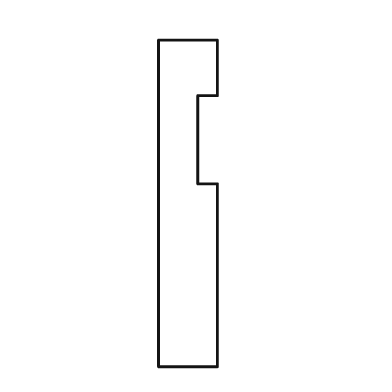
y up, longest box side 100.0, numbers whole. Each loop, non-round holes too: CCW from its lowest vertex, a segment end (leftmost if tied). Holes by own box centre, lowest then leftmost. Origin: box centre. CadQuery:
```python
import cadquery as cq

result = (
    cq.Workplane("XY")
    .moveTo(-9.0, -50.0)
    .lineTo(9.0, -50.0)
    .lineTo(9.0, 6.0)
    .lineTo(3.0, 6.0)
    .lineTo(3.0, 33.0)
    .lineTo(9.0, 33.0)
    .lineTo(9.0, 50.0)
    .lineTo(-9.0, 50.0)
    .close()
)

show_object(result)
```